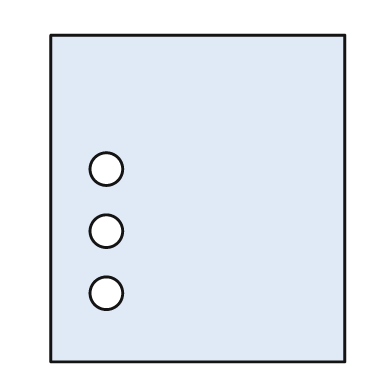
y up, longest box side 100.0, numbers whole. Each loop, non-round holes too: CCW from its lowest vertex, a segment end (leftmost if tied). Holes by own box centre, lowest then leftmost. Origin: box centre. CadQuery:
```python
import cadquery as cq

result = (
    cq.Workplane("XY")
    .moveTo(-45.0, -50.0)
    .lineTo(45.0, -50.0)
    .lineTo(45.0, 50.0)
    .lineTo(-45.0, 50.0)
    .close()
    .moveTo(-28.0, -29.0)
    .circle(5.0)
    .moveTo(-28.0, -10.0)
    .circle(5.0)
    .moveTo(-28.0, 9.0)
    .circle(5.0)
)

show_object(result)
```